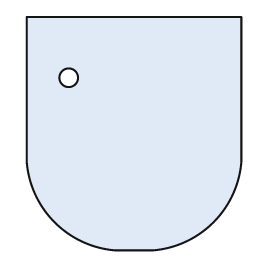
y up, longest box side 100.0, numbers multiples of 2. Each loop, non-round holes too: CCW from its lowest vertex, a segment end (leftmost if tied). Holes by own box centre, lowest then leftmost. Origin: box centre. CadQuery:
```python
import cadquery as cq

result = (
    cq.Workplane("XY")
    .moveTo(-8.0, -50.0)
    .lineTo(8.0, -50.0)
    .threePointArc((34.0, -38.0), (46.0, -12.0))
    .lineTo(46.0, 50.0)
    .lineTo(-46.0, 50.0)
    .lineTo(-46.0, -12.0)
    .threePointArc((-34.0, -38.0), (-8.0, -50.0))
    .close()
    .moveTo(-28.0, 24.0)
    .circle(4.0)
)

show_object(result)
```